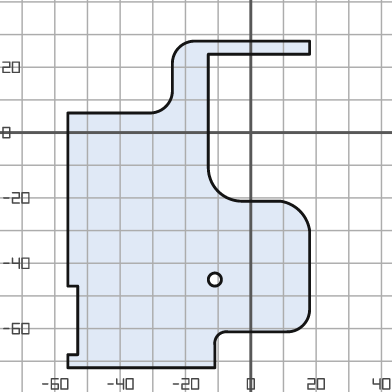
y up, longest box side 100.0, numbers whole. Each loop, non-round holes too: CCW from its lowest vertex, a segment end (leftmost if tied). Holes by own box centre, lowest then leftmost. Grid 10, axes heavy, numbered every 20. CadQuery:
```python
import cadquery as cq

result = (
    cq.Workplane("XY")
    .moveTo(-56.0, -72.0)
    .lineTo(-11.0, -72.0)
    .lineTo(-11.0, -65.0)
    .threePointArc((-10.0, -62.0), (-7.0, -61.0))
    .lineTo(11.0, -61.0)
    .threePointArc((16.0, -59.0), (18.0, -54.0))
    .lineTo(18.0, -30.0)
    .threePointArc((15.0, -24.0), (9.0, -21.0))
    .lineTo(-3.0, -21.0)
    .threePointArc((-10.0, -18.0), (-13.0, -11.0))
    .lineTo(-13.0, 24.0)
    .lineTo(18.0, 24.0)
    .lineTo(18.0, 28.0)
    .lineTo(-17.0, 28.0)
    .threePointArc((-22.0, 26.0), (-24.0, 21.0))
    .lineTo(-24.0, 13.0)
    .threePointArc((-26.0, 8.0), (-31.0, 6.0))
    .lineTo(-56.0, 6.0)
    .lineTo(-56.0, -47.0)
    .lineTo(-53.0, -47.0)
    .lineTo(-53.0, -68.0)
    .lineTo(-56.0, -68.0)
    .close()
    .moveTo(-11.0, -45.0)
    .circle(2.0)
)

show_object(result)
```